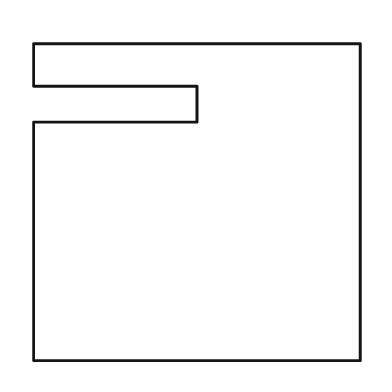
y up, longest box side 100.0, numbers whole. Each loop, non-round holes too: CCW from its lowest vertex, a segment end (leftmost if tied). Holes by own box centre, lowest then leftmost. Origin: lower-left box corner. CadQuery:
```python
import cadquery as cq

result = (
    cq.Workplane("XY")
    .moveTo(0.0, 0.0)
    .lineTo(100.0, 0.0)
    .lineTo(100.0, 97.0)
    .lineTo(0.0, 97.0)
    .lineTo(0.0, 84.0)
    .lineTo(50.0, 84.0)
    .lineTo(50.0, 73.0)
    .lineTo(0.0, 73.0)
    .close()
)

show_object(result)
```